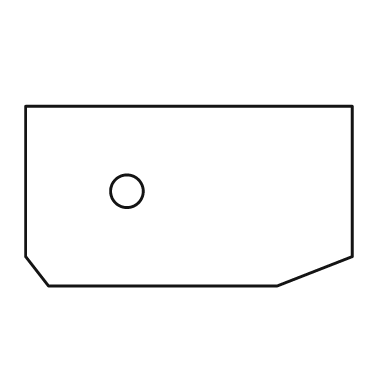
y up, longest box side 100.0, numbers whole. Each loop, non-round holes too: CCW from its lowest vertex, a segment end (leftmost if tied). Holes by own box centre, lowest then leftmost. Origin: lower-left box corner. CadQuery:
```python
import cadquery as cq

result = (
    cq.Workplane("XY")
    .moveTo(7.0, 0.0)
    .lineTo(77.0, 0.0)
    .lineTo(100.0, 9.0)
    .lineTo(100.0, 55.0)
    .lineTo(0.0, 55.0)
    .lineTo(0.0, 9.0)
    .close()
    .moveTo(31.0, 29.0)
    .circle(5.0)
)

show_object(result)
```